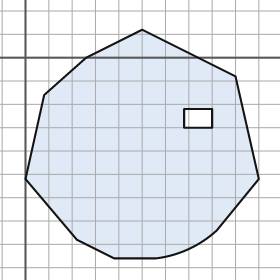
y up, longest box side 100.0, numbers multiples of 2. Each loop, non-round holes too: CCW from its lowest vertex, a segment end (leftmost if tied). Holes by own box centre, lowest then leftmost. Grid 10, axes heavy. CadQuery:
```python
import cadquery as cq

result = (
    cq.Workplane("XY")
    .moveTo(38.0, -86.0)
    .lineTo(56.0, -86.0)
    .threePointArc((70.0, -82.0), (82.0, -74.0))
    .lineTo(100.0, -52.0)
    .lineTo(90.0, -8.0)
    .lineTo(50.0, 12.0)
    .lineTo(26.0, 0.0)
    .lineTo(8.0, -16.0)
    .lineTo(0.0, -52.0)
    .lineTo(22.0, -78.0)
    .close()
    .moveTo(68.0, -30.0)
    .lineTo(80.0, -30.0)
    .lineTo(80.0, -22.0)
    .lineTo(68.0, -22.0)
    .close()
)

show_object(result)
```